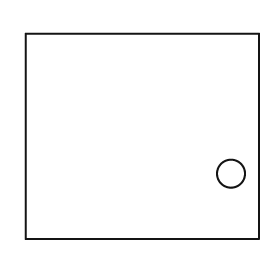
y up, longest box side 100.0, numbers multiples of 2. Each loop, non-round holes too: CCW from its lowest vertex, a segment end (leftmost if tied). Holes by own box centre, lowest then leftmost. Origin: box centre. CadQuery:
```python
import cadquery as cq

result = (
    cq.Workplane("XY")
    .moveTo(-50.0, -44.0)
    .lineTo(50.0, -44.0)
    .lineTo(50.0, 44.0)
    .lineTo(-50.0, 44.0)
    .close()
    .moveTo(38.0, -16.0)
    .circle(6.0)
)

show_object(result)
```